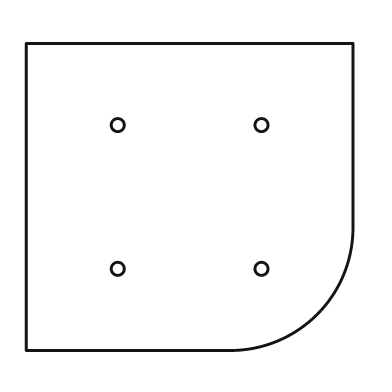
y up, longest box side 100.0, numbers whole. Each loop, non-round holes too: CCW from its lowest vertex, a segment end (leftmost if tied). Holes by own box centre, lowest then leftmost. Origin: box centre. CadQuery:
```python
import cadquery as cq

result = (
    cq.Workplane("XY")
    .moveTo(-50.0, -47.0)
    .lineTo(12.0, -47.0)
    .threePointArc((39.0, -36.0), (50.0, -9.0))
    .lineTo(50.0, 47.0)
    .lineTo(-50.0, 47.0)
    .close()
    .moveTo(-22.0, -22.0)
    .circle(2.0)
    .moveTo(22.0, -22.0)
    .circle(2.0)
    .moveTo(-22.0, 22.0)
    .circle(2.0)
    .moveTo(22.0, 22.0)
    .circle(2.0)
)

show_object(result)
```